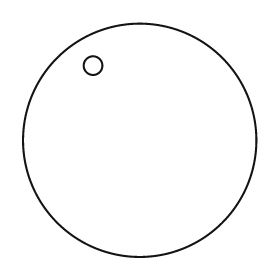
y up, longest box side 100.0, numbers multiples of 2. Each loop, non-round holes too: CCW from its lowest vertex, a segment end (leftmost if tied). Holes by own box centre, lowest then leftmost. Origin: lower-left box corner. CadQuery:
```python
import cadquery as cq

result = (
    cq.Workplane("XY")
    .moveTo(50.0, 50.0)
    .circle(50.0)
    .moveTo(30.0, 82.0)
    .circle(4.0)
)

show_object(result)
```